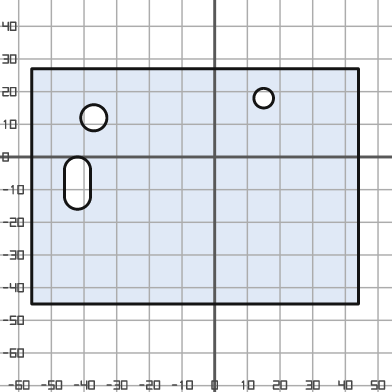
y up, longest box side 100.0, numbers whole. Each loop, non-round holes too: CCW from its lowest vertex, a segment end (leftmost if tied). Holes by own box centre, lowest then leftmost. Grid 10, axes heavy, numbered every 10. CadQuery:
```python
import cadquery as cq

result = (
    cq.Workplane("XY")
    .moveTo(-56.0, -45.0)
    .lineTo(44.0, -45.0)
    .lineTo(44.0, 27.0)
    .lineTo(-56.0, 27.0)
    .close()
    .moveTo(-46.0, -12.0)
    .threePointArc((-42.0, -16.0), (-38.0, -12.0))
    .lineTo(-38.0, -4.0)
    .threePointArc((-42.0, 0.0), (-46.0, -4.0))
    .close()
    .moveTo(-37.0, 12.0)
    .circle(4.0)
    .moveTo(15.0, 18.0)
    .circle(3.0)
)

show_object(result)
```